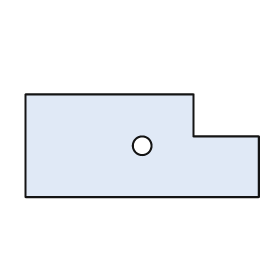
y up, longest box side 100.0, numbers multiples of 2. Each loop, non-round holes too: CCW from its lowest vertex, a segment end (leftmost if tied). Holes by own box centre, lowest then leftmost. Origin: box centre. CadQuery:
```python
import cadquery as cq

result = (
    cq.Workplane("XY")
    .moveTo(-50.0, -22.0)
    .lineTo(50.0, -22.0)
    .lineTo(50.0, 4.0)
    .lineTo(22.0, 4.0)
    .lineTo(22.0, 22.0)
    .lineTo(-50.0, 22.0)
    .close()
    .moveTo(0.0, 0.0)
    .circle(4.0)
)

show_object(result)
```